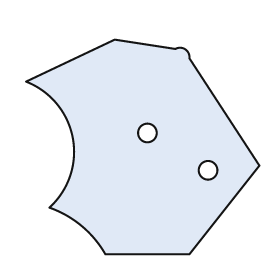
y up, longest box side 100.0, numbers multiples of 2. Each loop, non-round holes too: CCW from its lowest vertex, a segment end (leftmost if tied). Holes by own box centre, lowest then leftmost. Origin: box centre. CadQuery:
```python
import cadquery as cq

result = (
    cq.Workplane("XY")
    .moveTo(-16.0, -46.0)
    .lineTo(20.0, -46.0)
    .lineTo(50.0, -8.0)
    .lineTo(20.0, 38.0)
    .threePointArc((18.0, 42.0), (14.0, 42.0))
    .lineTo(-12.0, 46.0)
    .lineTo(-50.0, 28.0)
    .threePointArc((-30.0, 4.0), (-40.0, -26.0))
    .threePointArc((-26.0, -34.0), (-16.0, -46.0))
    .close()
    .moveTo(28.0, -10.0)
    .circle(4.0)
    .moveTo(2.0, 6.0)
    .circle(4.0)
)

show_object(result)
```